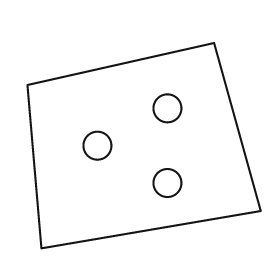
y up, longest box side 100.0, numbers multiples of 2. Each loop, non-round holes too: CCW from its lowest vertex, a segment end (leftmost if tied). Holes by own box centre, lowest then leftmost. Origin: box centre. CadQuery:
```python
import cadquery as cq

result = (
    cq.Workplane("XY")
    .moveTo(-44.0, -44.0)
    .lineTo(50.0, -28.0)
    .lineTo(30.0, 44.0)
    .lineTo(-50.0, 26.0)
    .close()
    .moveTo(10.0, -16.0)
    .circle(6.0)
    .moveTo(-20.0, 0.0)
    .circle(6.0)
    .moveTo(10.0, 16.0)
    .circle(6.0)
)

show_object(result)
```